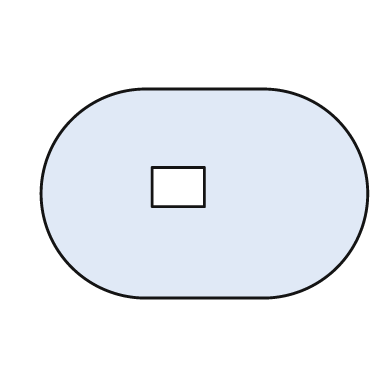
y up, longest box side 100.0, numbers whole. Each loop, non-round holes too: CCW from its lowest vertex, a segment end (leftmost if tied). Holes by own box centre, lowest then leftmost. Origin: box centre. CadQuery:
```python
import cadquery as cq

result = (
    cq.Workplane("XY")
    .moveTo(-18.0, -32.0)
    .lineTo(18.0, -32.0)
    .threePointArc((50.0, 0.0), (18.0, 32.0))
    .lineTo(-18.0, 32.0)
    .threePointArc((-50.0, 0.0), (-18.0, -32.0))
    .close()
    .moveTo(-16.0, -4.0)
    .lineTo(0.0, -4.0)
    .lineTo(0.0, 8.0)
    .lineTo(-16.0, 8.0)
    .close()
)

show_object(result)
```